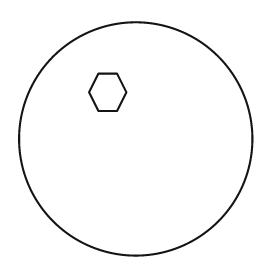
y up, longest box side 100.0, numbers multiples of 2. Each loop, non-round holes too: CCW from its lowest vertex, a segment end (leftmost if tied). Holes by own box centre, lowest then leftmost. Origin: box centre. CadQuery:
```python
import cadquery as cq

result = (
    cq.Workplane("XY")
    .moveTo(0.0, 0.0)
    .circle(50.0)
    .moveTo(-16.0, 12.0)
    .lineTo(-8.0, 12.0)
    .lineTo(-4.0, 20.0)
    .lineTo(-8.0, 28.0)
    .lineTo(-16.0, 28.0)
    .lineTo(-20.0, 20.0)
    .close()
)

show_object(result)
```